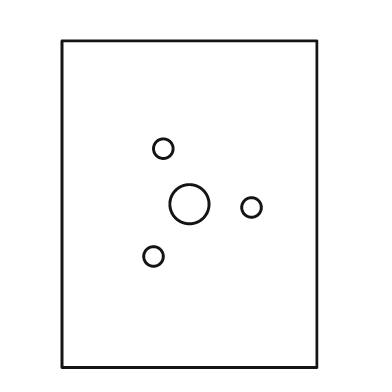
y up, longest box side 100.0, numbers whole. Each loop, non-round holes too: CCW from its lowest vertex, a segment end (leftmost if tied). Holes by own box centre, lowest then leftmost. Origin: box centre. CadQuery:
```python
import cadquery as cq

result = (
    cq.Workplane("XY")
    .moveTo(-39.0, -50.0)
    .lineTo(39.0, -50.0)
    .lineTo(39.0, 50.0)
    .lineTo(-39.0, 50.0)
    .close()
    .moveTo(-11.0, -16.0)
    .circle(3.0)
    .moveTo(19.0, -1.0)
    .circle(3.0)
    .moveTo(0.0, 0.0)
    .circle(6.0)
    .moveTo(-8.0, 17.0)
    .circle(3.0)
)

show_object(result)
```